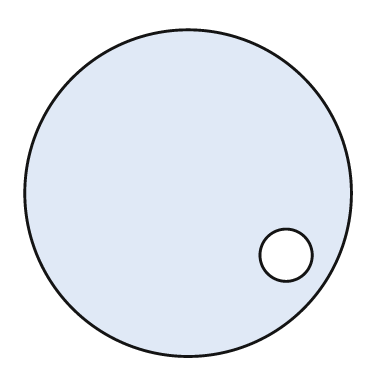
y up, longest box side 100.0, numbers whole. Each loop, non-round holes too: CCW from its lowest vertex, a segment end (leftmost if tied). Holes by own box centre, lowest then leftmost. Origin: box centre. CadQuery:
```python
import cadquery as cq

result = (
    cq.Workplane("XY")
    .moveTo(0.0, 0.0)
    .circle(50.0)
    .moveTo(30.0, -19.0)
    .circle(8.0)
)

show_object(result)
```